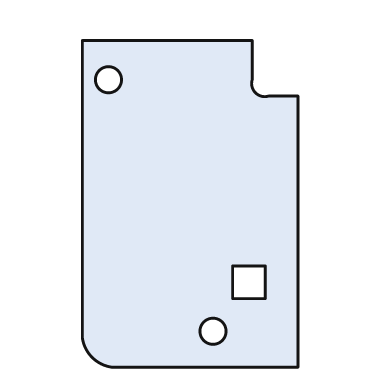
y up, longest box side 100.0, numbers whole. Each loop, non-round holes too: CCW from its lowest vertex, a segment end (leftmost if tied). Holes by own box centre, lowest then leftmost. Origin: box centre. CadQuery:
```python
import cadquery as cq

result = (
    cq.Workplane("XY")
    .moveTo(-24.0, -50.0)
    .lineTo(33.0, -50.0)
    .lineTo(33.0, 33.0)
    .lineTo(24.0, 33.0)
    .threePointArc((20.0, 34.0), (19.0, 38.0))
    .lineTo(19.0, 50.0)
    .lineTo(-33.0, 50.0)
    .lineTo(-33.0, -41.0)
    .threePointArc((-30.0, -47.0), (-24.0, -50.0))
    .close()
    .moveTo(7.0, -39.0)
    .circle(4.0)
    .moveTo(13.0, -29.0)
    .lineTo(23.0, -29.0)
    .lineTo(23.0, -19.0)
    .lineTo(13.0, -19.0)
    .close()
    .moveTo(-25.0, 38.0)
    .circle(4.0)
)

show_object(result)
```